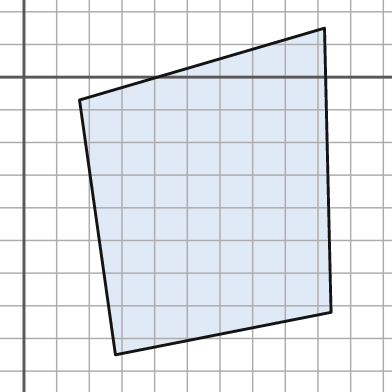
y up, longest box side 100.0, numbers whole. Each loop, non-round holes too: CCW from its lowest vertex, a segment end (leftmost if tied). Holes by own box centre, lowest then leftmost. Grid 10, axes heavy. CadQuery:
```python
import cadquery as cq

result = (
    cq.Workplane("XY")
    .moveTo(28.0, -85.0)
    .lineTo(94.0, -72.0)
    .lineTo(92.0, 15.0)
    .lineTo(17.0, -7.0)
    .close()
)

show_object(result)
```